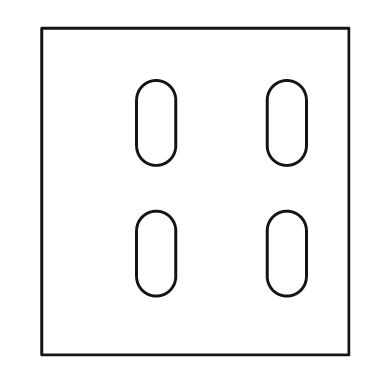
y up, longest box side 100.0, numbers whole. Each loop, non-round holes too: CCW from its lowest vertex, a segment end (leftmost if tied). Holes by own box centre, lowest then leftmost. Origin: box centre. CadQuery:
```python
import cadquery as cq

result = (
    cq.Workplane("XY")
    .moveTo(-47.0, -50.0)
    .lineTo(47.0, -50.0)
    .lineTo(47.0, 50.0)
    .lineTo(-47.0, 50.0)
    .close()
    .moveTo(-18.0, -26.0)
    .threePointArc((-12.0, -32.0), (-6.0, -26.0))
    .lineTo(-6.0, -12.0)
    .threePointArc((-12.0, -6.0), (-18.0, -12.0))
    .close()
    .moveTo(22.0, -26.0)
    .threePointArc((28.0, -32.0), (34.0, -26.0))
    .lineTo(34.0, -12.0)
    .threePointArc((28.0, -6.0), (22.0, -12.0))
    .close()
    .moveTo(-18.0, 14.0)
    .threePointArc((-12.0, 8.0), (-6.0, 14.0))
    .lineTo(-6.0, 28.0)
    .threePointArc((-12.0, 34.0), (-18.0, 28.0))
    .close()
    .moveTo(22.0, 14.0)
    .threePointArc((28.0, 8.0), (34.0, 14.0))
    .lineTo(34.0, 28.0)
    .threePointArc((28.0, 34.0), (22.0, 28.0))
    .close()
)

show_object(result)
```